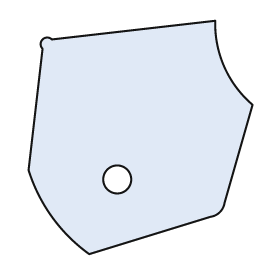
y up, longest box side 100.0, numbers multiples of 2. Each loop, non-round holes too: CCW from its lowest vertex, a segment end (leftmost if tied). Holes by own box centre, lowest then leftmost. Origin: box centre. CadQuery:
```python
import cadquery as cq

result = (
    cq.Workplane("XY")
    .moveTo(-22.0, -50.0)
    .lineTo(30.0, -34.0)
    .threePointArc((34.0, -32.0), (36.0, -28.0))
    .lineTo(48.0, 14.0)
    .threePointArc((36.0, 30.0), (32.0, 50.0))
    .lineTo(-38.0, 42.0)
    .threePointArc((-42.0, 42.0), (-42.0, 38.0))
    .lineTo(-48.0, -14.0)
    .threePointArc((-38.0, -34.0), (-22.0, -50.0))
    .close()
    .moveTo(-10.0, -18.0)
    .circle(6.0)
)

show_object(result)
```